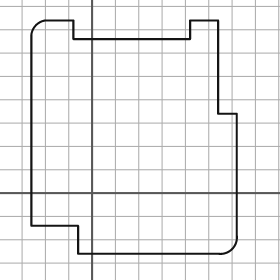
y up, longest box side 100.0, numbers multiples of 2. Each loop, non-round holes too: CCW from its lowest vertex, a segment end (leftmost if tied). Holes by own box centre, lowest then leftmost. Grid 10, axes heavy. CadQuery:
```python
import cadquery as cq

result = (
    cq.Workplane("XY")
    .moveTo(-6.0, -26.0)
    .lineTo(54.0, -26.0)
    .threePointArc((60.0, -24.0), (62.0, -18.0))
    .lineTo(62.0, 34.0)
    .lineTo(54.0, 34.0)
    .lineTo(54.0, 74.0)
    .lineTo(42.0, 74.0)
    .lineTo(42.0, 66.0)
    .lineTo(-8.0, 66.0)
    .lineTo(-8.0, 74.0)
    .lineTo(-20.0, 74.0)
    .threePointArc((-24.0, 72.0), (-26.0, 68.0))
    .lineTo(-26.0, -14.0)
    .lineTo(-6.0, -14.0)
    .close()
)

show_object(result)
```